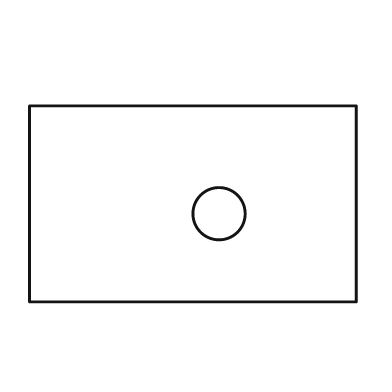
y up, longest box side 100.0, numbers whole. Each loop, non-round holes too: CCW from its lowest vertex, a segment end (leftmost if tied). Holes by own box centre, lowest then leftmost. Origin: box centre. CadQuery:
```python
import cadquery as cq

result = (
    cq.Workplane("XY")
    .moveTo(-50.0, -30.0)
    .lineTo(50.0, -30.0)
    .lineTo(50.0, 30.0)
    .lineTo(-50.0, 30.0)
    .close()
    .moveTo(8.0, -3.0)
    .circle(8.0)
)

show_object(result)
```